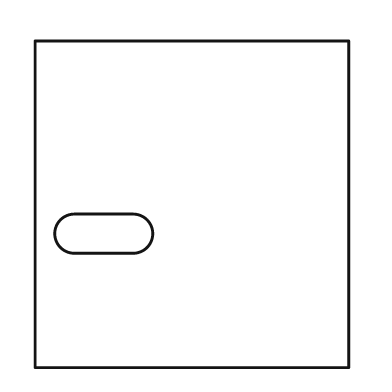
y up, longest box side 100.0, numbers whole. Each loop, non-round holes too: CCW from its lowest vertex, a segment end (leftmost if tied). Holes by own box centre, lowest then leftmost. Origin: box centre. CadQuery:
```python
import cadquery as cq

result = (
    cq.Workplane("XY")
    .moveTo(-48.0, -50.0)
    .lineTo(48.0, -50.0)
    .lineTo(48.0, 50.0)
    .lineTo(-48.0, 50.0)
    .close()
    .moveTo(-36.0, -15.0)
    .lineTo(-18.0, -15.0)
    .threePointArc((-12.0, -9.0), (-18.0, -3.0))
    .lineTo(-36.0, -3.0)
    .threePointArc((-42.0, -9.0), (-36.0, -15.0))
    .close()
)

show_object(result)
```